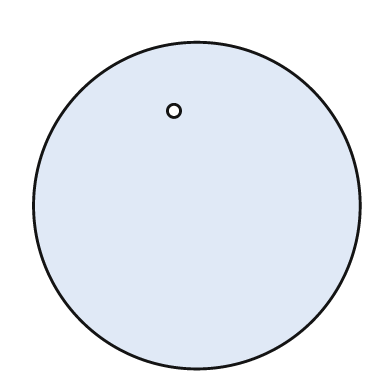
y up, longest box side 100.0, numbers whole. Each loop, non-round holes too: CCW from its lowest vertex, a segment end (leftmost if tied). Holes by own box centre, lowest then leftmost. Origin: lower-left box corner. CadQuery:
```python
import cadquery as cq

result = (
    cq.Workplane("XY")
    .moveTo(50.0, 50.0)
    .circle(50.0)
    .moveTo(43.0, 79.0)
    .circle(2.0)
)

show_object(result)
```